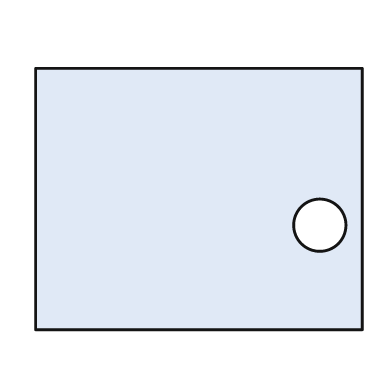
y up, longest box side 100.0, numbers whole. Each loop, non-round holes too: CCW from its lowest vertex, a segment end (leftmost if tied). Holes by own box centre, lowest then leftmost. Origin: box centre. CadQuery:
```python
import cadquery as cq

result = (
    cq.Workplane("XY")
    .moveTo(-50.0, -40.0)
    .lineTo(50.0, -40.0)
    .lineTo(50.0, 40.0)
    .lineTo(-50.0, 40.0)
    .close()
    .moveTo(37.0, -8.0)
    .circle(8.0)
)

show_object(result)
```